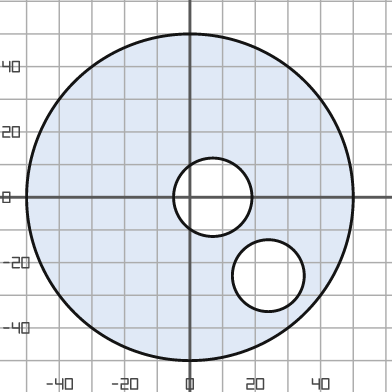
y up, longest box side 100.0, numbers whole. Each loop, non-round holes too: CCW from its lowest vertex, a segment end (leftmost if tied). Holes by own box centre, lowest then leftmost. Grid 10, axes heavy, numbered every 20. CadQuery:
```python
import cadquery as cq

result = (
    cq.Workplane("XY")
    .moveTo(0.0, 0.0)
    .circle(50.0)
    .moveTo(24.0, -24.0)
    .circle(11.0)
    .moveTo(7.0, 0.0)
    .circle(12.0)
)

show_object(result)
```